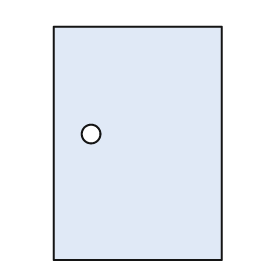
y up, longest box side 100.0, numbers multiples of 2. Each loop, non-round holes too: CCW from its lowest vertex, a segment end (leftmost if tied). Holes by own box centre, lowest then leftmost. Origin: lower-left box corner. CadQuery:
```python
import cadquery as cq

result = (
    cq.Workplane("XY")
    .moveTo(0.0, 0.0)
    .lineTo(72.0, 0.0)
    .lineTo(72.0, 100.0)
    .lineTo(0.0, 100.0)
    .close()
    .moveTo(16.0, 54.0)
    .circle(4.0)
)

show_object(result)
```